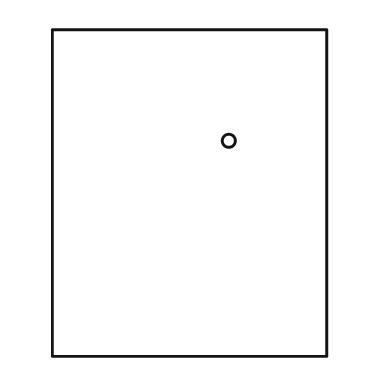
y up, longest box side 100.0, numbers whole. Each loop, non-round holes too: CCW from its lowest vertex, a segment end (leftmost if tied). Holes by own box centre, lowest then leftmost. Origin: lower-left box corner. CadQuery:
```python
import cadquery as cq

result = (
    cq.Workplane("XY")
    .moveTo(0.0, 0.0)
    .lineTo(84.0, 0.0)
    .lineTo(84.0, 100.0)
    .lineTo(0.0, 100.0)
    .close()
    .moveTo(54.0, 66.0)
    .circle(2.0)
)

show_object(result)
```